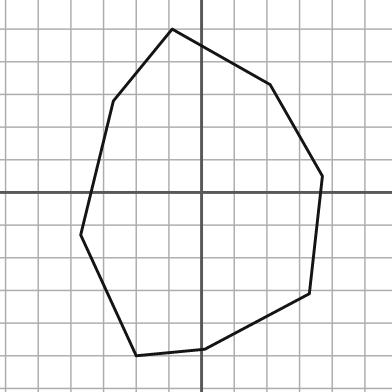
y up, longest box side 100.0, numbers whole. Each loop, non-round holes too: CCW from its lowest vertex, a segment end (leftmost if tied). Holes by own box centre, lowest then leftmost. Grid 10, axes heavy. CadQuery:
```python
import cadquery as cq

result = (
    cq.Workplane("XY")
    .moveTo(-20.0, -50.0)
    .lineTo(1.0, -48.0)
    .lineTo(33.0, -31.0)
    .lineTo(37.0, 5.0)
    .lineTo(21.0, 33.0)
    .lineTo(-9.0, 50.0)
    .lineTo(-27.0, 28.0)
    .lineTo(-37.0, -13.0)
    .close()
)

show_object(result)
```